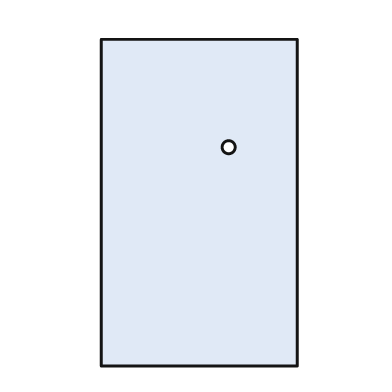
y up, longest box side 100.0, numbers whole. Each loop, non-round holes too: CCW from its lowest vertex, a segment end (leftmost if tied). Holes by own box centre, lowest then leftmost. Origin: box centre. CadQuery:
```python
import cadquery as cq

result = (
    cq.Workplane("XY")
    .moveTo(-30.0, -50.0)
    .lineTo(30.0, -50.0)
    .lineTo(30.0, 50.0)
    .lineTo(-30.0, 50.0)
    .close()
    .moveTo(9.0, 17.0)
    .circle(2.0)
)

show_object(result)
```